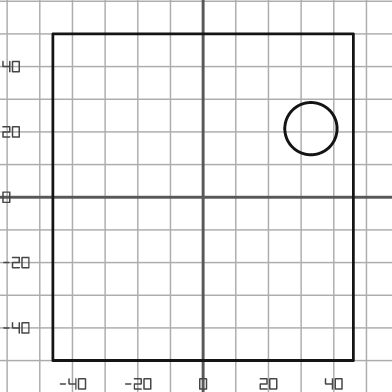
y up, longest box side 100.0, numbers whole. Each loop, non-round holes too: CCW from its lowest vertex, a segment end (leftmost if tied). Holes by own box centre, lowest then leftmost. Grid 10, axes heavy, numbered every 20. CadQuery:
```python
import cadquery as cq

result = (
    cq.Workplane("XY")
    .moveTo(-46.0, -50.0)
    .lineTo(46.0, -50.0)
    .lineTo(46.0, 50.0)
    .lineTo(-46.0, 50.0)
    .close()
    .moveTo(33.0, 21.0)
    .circle(8.0)
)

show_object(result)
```